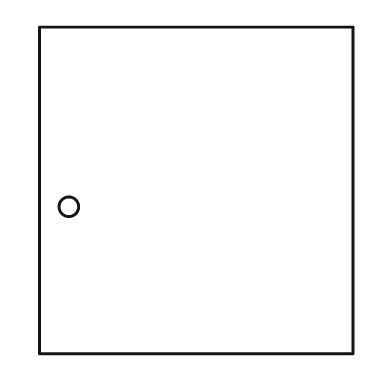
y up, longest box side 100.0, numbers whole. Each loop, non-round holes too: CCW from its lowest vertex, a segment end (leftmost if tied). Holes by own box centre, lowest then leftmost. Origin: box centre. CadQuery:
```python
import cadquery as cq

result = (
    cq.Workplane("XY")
    .moveTo(-48.0, -50.0)
    .lineTo(48.0, -50.0)
    .lineTo(48.0, 50.0)
    .lineTo(-48.0, 50.0)
    .close()
    .moveTo(-39.0, -5.0)
    .circle(3.0)
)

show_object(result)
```